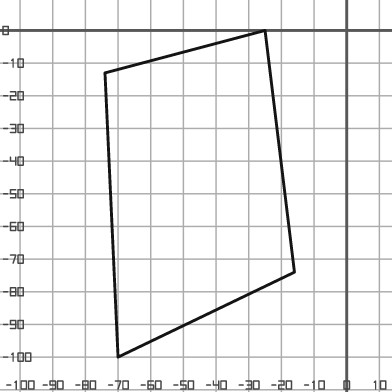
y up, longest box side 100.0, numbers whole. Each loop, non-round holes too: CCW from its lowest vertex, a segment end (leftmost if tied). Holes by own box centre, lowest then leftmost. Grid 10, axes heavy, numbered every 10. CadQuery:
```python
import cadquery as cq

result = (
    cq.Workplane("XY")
    .moveTo(-70.0, -100.0)
    .lineTo(-16.0, -74.0)
    .lineTo(-25.0, 0.0)
    .lineTo(-74.0, -13.0)
    .close()
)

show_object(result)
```